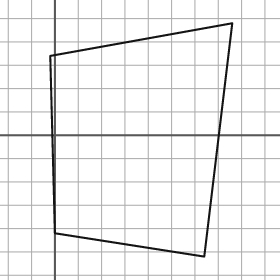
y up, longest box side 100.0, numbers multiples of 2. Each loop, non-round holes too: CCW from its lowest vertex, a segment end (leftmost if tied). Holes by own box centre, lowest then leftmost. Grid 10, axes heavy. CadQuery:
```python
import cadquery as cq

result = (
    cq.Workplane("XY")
    .moveTo(64.0, -52.0)
    .lineTo(76.0, 48.0)
    .lineTo(-2.0, 34.0)
    .lineTo(0.0, -42.0)
    .close()
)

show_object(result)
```